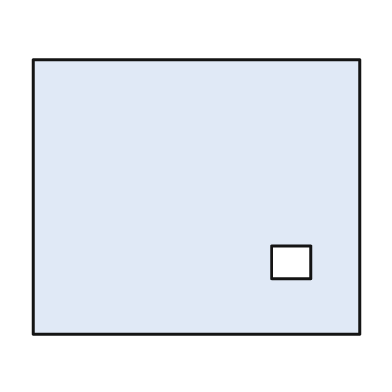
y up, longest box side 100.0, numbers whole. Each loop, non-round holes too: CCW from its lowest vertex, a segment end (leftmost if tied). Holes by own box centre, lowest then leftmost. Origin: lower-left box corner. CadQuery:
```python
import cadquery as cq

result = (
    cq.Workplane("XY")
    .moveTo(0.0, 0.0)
    .lineTo(100.0, 0.0)
    .lineTo(100.0, 84.0)
    .lineTo(0.0, 84.0)
    .close()
    .moveTo(73.0, 17.0)
    .lineTo(85.0, 17.0)
    .lineTo(85.0, 27.0)
    .lineTo(73.0, 27.0)
    .close()
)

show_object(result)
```